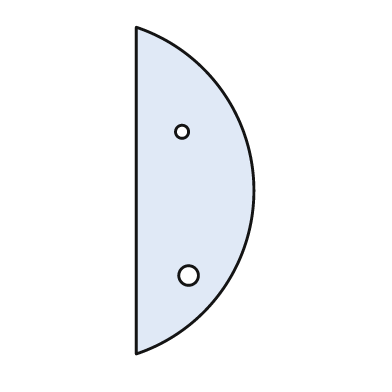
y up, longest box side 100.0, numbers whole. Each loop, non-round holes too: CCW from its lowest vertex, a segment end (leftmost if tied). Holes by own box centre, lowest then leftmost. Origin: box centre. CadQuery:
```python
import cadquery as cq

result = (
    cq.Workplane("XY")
    .moveTo(-18.0, -50.0)
    .threePointArc((18.0, 0.0), (-18.0, 50.0))
    .close()
    .moveTo(-2.0, -26.0)
    .circle(3.0)
    .moveTo(-4.0, 18.0)
    .circle(2.0)
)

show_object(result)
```